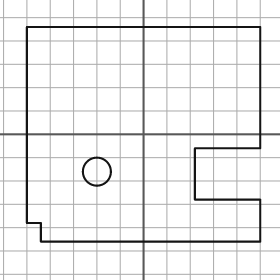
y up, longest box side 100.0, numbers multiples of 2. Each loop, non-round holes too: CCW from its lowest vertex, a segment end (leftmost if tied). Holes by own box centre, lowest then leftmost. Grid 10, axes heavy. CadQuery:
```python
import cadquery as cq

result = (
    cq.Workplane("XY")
    .moveTo(-44.0, -46.0)
    .lineTo(50.0, -46.0)
    .lineTo(50.0, -28.0)
    .lineTo(22.0, -28.0)
    .lineTo(22.0, -6.0)
    .lineTo(50.0, -6.0)
    .lineTo(50.0, 46.0)
    .lineTo(-50.0, 46.0)
    .lineTo(-50.0, -38.0)
    .lineTo(-44.0, -38.0)
    .close()
    .moveTo(-20.0, -16.0)
    .circle(6.0)
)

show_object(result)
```